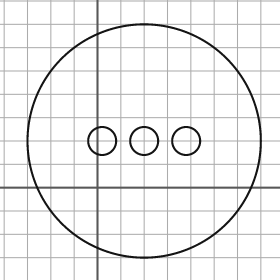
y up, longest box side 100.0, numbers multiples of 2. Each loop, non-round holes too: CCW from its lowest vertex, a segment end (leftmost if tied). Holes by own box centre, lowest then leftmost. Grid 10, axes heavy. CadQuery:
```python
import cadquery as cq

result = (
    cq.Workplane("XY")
    .moveTo(20.0, 20.0)
    .circle(50.0)
    .moveTo(2.0, 20.0)
    .circle(6.0)
    .moveTo(20.0, 20.0)
    .circle(6.0)
    .moveTo(38.0, 20.0)
    .circle(6.0)
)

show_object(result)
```